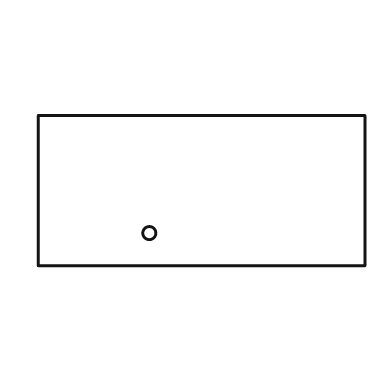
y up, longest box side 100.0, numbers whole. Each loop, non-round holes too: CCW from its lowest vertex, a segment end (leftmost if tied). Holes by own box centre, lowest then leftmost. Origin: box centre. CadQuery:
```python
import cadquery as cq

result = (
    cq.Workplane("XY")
    .moveTo(-50.0, -23.0)
    .lineTo(50.0, -23.0)
    .lineTo(50.0, 23.0)
    .lineTo(-50.0, 23.0)
    .close()
    .moveTo(-16.0, -13.0)
    .circle(2.0)
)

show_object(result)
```